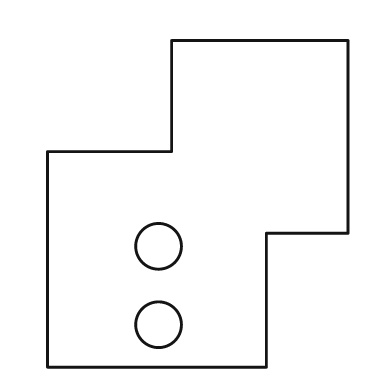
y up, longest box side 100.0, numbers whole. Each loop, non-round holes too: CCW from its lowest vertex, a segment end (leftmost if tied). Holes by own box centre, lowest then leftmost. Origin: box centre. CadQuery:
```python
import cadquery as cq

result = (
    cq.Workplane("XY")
    .moveTo(-46.0, -50.0)
    .lineTo(21.0, -50.0)
    .lineTo(21.0, -9.0)
    .lineTo(46.0, -9.0)
    .lineTo(46.0, 50.0)
    .lineTo(-8.0, 50.0)
    .lineTo(-8.0, 16.0)
    .lineTo(-46.0, 16.0)
    .close()
    .moveTo(-12.0, -37.0)
    .circle(7.0)
    .moveTo(-12.0, -13.0)
    .circle(7.0)
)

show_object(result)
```